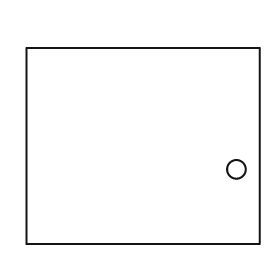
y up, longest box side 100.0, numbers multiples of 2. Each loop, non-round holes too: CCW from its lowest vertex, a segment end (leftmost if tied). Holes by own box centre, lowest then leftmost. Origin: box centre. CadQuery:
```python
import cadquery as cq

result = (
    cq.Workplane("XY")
    .moveTo(-50.0, -42.0)
    .lineTo(50.0, -42.0)
    .lineTo(50.0, 42.0)
    .lineTo(-50.0, 42.0)
    .close()
    .moveTo(40.0, -10.0)
    .circle(4.0)
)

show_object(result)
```